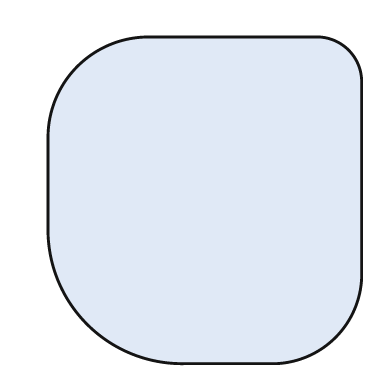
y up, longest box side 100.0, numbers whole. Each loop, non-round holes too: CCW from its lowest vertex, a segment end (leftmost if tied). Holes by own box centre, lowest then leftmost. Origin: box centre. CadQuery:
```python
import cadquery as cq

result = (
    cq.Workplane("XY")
    .moveTo(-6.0, -50.0)
    .lineTo(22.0, -50.0)
    .threePointArc((40.0, -42.0), (48.0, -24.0))
    .lineTo(48.0, 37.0)
    .threePointArc((44.0, 46.0), (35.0, 50.0))
    .lineTo(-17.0, 50.0)
    .threePointArc((-39.0, 41.0), (-48.0, 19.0))
    .lineTo(-48.0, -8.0)
    .threePointArc((-36.0, -38.0), (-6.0, -50.0))
    .close()
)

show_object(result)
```